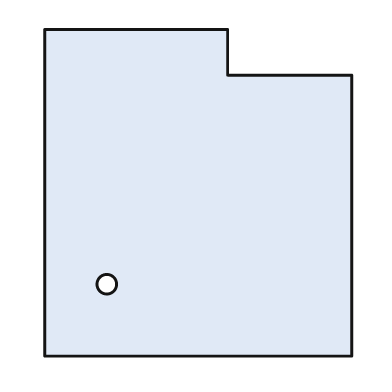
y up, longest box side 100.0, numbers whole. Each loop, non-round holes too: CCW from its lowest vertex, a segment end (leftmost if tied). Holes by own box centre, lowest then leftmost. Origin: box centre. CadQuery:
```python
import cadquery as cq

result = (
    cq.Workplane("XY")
    .moveTo(-47.0, -50.0)
    .lineTo(47.0, -50.0)
    .lineTo(47.0, 36.0)
    .lineTo(9.0, 36.0)
    .lineTo(9.0, 50.0)
    .lineTo(-47.0, 50.0)
    .close()
    .moveTo(-28.0, -28.0)
    .circle(3.0)
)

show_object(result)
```